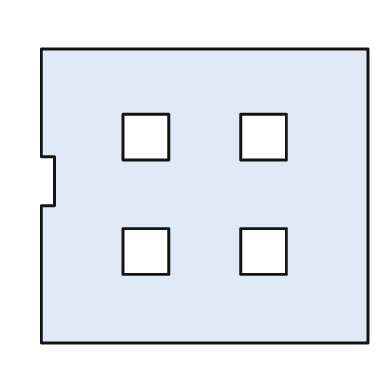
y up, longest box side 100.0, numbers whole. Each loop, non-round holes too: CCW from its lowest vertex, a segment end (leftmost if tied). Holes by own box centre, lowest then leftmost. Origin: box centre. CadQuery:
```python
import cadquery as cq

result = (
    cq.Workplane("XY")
    .moveTo(-50.0, -45.0)
    .lineTo(50.0, -45.0)
    .lineTo(50.0, 45.0)
    .lineTo(-50.0, 45.0)
    .lineTo(-50.0, 12.0)
    .lineTo(-46.0, 12.0)
    .lineTo(-46.0, -3.0)
    .lineTo(-50.0, -3.0)
    .close()
    .moveTo(-25.0, -24.0)
    .lineTo(-11.0, -24.0)
    .lineTo(-11.0, -10.0)
    .lineTo(-25.0, -10.0)
    .close()
    .moveTo(11.0, -24.0)
    .lineTo(25.0, -24.0)
    .lineTo(25.0, -10.0)
    .lineTo(11.0, -10.0)
    .close()
    .moveTo(-25.0, 11.0)
    .lineTo(-11.0, 11.0)
    .lineTo(-11.0, 25.0)
    .lineTo(-25.0, 25.0)
    .close()
    .moveTo(11.0, 11.0)
    .lineTo(25.0, 11.0)
    .lineTo(25.0, 25.0)
    .lineTo(11.0, 25.0)
    .close()
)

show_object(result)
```